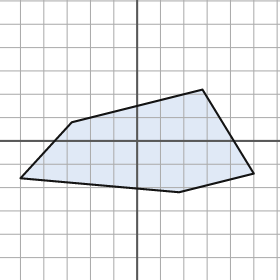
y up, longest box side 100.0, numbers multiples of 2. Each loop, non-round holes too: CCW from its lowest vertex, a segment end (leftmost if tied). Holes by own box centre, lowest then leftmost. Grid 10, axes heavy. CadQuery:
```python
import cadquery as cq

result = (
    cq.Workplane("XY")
    .moveTo(18.0, -22.0)
    .lineTo(50.0, -14.0)
    .lineTo(28.0, 22.0)
    .lineTo(-28.0, 8.0)
    .lineTo(-50.0, -16.0)
    .close()
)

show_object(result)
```